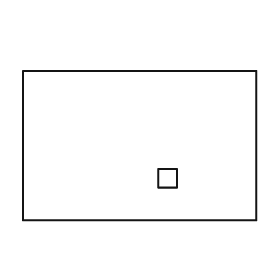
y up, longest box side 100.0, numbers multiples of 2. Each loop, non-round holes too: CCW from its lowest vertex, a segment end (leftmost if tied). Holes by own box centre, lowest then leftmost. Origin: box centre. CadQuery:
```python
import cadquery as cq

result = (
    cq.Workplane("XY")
    .moveTo(-50.0, -32.0)
    .lineTo(50.0, -32.0)
    .lineTo(50.0, 32.0)
    .lineTo(-50.0, 32.0)
    .close()
    .moveTo(8.0, -18.0)
    .lineTo(16.0, -18.0)
    .lineTo(16.0, -10.0)
    .lineTo(8.0, -10.0)
    .close()
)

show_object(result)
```